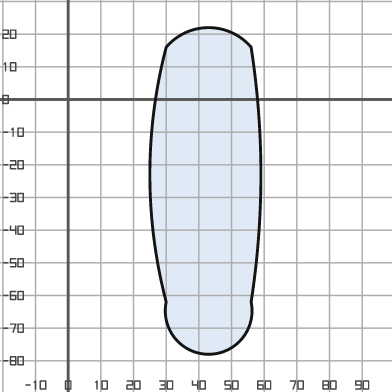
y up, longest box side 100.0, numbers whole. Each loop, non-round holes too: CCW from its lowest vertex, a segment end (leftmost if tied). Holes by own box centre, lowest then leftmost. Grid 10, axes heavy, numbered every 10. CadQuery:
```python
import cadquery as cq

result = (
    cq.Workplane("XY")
    .moveTo(30.0, -62.0)
    .threePointArc((43.0, -78.0), (56.0, -62.0))
    .threePointArc((59.0, -23.0), (56.0, 16.0))
    .threePointArc((43.0, 22.0), (30.0, 16.0))
    .threePointArc((25.0, -23.0), (30.0, -62.0))
    .close()
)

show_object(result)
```